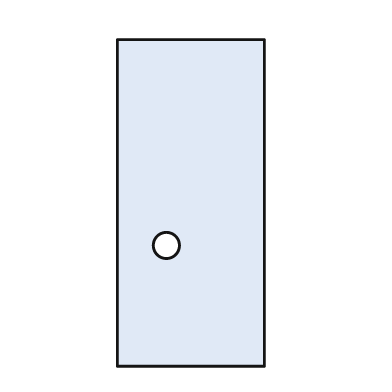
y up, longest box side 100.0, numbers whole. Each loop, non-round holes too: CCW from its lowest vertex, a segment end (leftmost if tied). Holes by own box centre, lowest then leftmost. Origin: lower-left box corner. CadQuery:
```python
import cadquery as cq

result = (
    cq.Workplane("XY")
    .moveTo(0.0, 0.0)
    .lineTo(45.0, 0.0)
    .lineTo(45.0, 100.0)
    .lineTo(0.0, 100.0)
    .close()
    .moveTo(15.0, 37.0)
    .circle(4.0)
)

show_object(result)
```